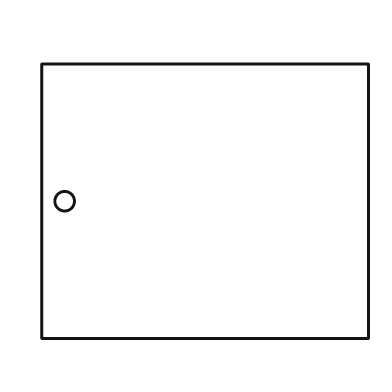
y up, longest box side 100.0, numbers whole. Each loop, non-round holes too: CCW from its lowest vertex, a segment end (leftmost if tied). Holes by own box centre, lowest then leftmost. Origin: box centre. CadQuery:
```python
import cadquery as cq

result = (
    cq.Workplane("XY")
    .moveTo(-50.0, -42.0)
    .lineTo(50.0, -42.0)
    .lineTo(50.0, 42.0)
    .lineTo(-50.0, 42.0)
    .close()
    .moveTo(-43.0, 0.0)
    .circle(3.0)
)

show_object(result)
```